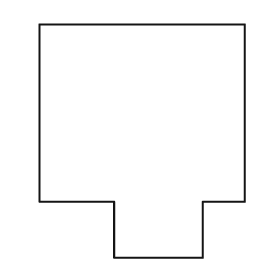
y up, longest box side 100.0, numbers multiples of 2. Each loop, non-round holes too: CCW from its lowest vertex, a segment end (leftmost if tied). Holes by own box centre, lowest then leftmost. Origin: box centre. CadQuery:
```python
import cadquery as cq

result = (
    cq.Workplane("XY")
    .moveTo(-12.0, -50.0)
    .lineTo(26.0, -50.0)
    .lineTo(26.0, -26.0)
    .lineTo(44.0, -26.0)
    .lineTo(44.0, 50.0)
    .lineTo(-44.0, 50.0)
    .lineTo(-44.0, -26.0)
    .lineTo(-12.0, -26.0)
    .close()
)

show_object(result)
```